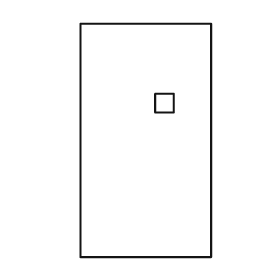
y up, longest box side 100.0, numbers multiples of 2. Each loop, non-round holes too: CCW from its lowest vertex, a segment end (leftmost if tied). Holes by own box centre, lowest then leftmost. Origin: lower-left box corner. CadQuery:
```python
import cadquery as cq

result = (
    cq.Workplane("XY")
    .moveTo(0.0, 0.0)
    .lineTo(56.0, 0.0)
    .lineTo(56.0, 100.0)
    .lineTo(0.0, 100.0)
    .close()
    .moveTo(32.0, 62.0)
    .lineTo(40.0, 62.0)
    .lineTo(40.0, 70.0)
    .lineTo(32.0, 70.0)
    .close()
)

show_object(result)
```